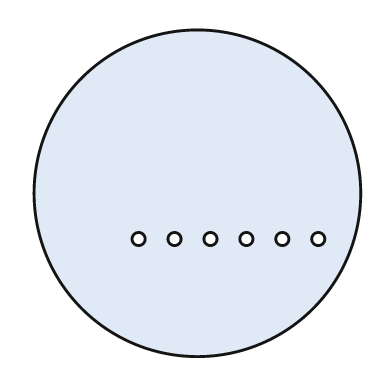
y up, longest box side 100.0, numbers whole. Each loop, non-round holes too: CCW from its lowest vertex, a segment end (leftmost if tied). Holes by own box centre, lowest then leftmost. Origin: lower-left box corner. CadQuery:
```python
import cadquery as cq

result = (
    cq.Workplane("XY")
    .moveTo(50.0, 50.0)
    .circle(50.0)
    .moveTo(32.0, 36.0)
    .circle(2.0)
    .moveTo(43.0, 36.0)
    .circle(2.0)
    .moveTo(54.0, 36.0)
    .circle(2.0)
    .moveTo(65.0, 36.0)
    .circle(2.0)
    .moveTo(76.0, 36.0)
    .circle(2.0)
    .moveTo(87.0, 36.0)
    .circle(2.0)
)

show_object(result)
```